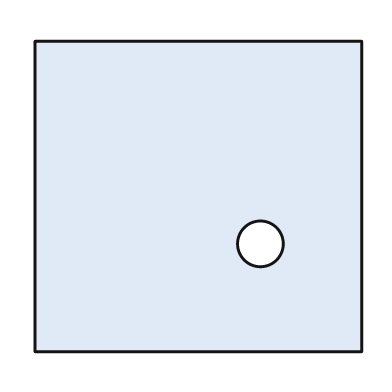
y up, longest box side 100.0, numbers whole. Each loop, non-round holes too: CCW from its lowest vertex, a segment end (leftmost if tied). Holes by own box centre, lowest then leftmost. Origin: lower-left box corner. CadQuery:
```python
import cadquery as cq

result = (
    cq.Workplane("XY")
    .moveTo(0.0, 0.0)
    .lineTo(100.0, 0.0)
    .lineTo(100.0, 95.0)
    .lineTo(0.0, 95.0)
    .close()
    .moveTo(69.0, 33.0)
    .circle(7.0)
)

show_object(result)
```